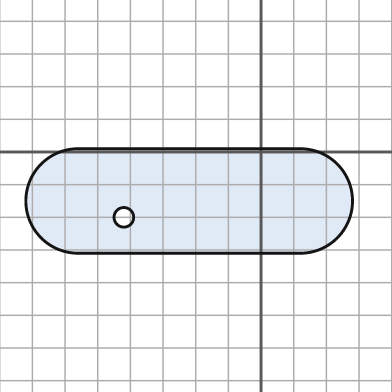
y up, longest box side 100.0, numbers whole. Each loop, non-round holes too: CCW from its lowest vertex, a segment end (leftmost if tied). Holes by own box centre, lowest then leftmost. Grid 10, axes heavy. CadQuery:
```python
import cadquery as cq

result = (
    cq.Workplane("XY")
    .moveTo(-56.0, -31.0)
    .lineTo(12.0, -31.0)
    .threePointArc((28.0, -15.0), (12.0, 1.0))
    .lineTo(-56.0, 1.0)
    .threePointArc((-72.0, -15.0), (-56.0, -31.0))
    .close()
    .moveTo(-42.0, -20.0)
    .circle(3.0)
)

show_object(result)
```